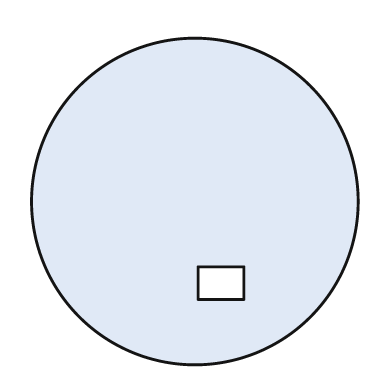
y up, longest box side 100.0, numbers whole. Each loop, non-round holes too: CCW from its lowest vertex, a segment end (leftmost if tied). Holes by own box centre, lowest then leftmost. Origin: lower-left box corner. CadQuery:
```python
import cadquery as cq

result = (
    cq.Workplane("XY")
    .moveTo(50.0, 50.0)
    .circle(50.0)
    .moveTo(51.0, 20.0)
    .lineTo(65.0, 20.0)
    .lineTo(65.0, 30.0)
    .lineTo(51.0, 30.0)
    .close()
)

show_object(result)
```